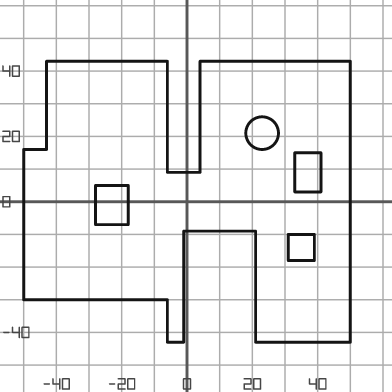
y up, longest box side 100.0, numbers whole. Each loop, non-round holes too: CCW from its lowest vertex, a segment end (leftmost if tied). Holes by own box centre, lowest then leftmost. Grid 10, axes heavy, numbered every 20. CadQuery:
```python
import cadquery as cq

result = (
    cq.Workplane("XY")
    .moveTo(-6.0, -43.0)
    .lineTo(-1.0, -43.0)
    .lineTo(-1.0, -9.0)
    .lineTo(21.0, -9.0)
    .lineTo(21.0, -43.0)
    .lineTo(50.0, -43.0)
    .lineTo(50.0, 43.0)
    .lineTo(4.0, 43.0)
    .lineTo(4.0, 9.0)
    .lineTo(-6.0, 9.0)
    .lineTo(-6.0, 43.0)
    .lineTo(-43.0, 43.0)
    .lineTo(-43.0, 16.0)
    .lineTo(-50.0, 16.0)
    .lineTo(-50.0, -30.0)
    .lineTo(-6.0, -30.0)
    .close()
    .moveTo(31.0, -18.0)
    .lineTo(39.0, -18.0)
    .lineTo(39.0, -10.0)
    .lineTo(31.0, -10.0)
    .close()
    .moveTo(-28.0, -7.0)
    .lineTo(-18.0, -7.0)
    .lineTo(-18.0, 5.0)
    .lineTo(-28.0, 5.0)
    .close()
    .moveTo(33.0, 3.0)
    .lineTo(41.0, 3.0)
    .lineTo(41.0, 15.0)
    .lineTo(33.0, 15.0)
    .close()
    .moveTo(23.0, 21.0)
    .circle(5.0)
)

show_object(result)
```